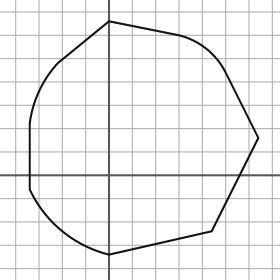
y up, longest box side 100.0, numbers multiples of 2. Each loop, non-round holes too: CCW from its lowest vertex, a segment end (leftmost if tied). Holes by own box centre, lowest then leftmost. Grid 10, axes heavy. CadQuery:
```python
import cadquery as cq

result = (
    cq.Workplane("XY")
    .moveTo(0.0, -34.0)
    .lineTo(44.0, -24.0)
    .lineTo(64.0, 16.0)
    .lineTo(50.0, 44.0)
    .threePointArc((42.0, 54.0), (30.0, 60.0))
    .lineTo(0.0, 66.0)
    .lineTo(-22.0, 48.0)
    .threePointArc((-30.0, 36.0), (-34.0, 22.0))
    .lineTo(-34.0, -6.0)
    .threePointArc((-20.0, -24.0), (0.0, -34.0))
    .close()
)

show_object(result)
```